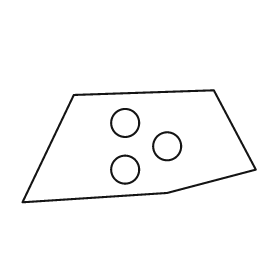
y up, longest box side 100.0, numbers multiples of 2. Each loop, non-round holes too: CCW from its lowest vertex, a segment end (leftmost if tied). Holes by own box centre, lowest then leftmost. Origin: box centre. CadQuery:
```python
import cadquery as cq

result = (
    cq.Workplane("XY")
    .moveTo(-50.0, -24.0)
    .lineTo(12.0, -20.0)
    .lineTo(50.0, -10.0)
    .lineTo(32.0, 24.0)
    .lineTo(-28.0, 22.0)
    .close()
    .moveTo(-6.0, -10.0)
    .circle(6.0)
    .moveTo(12.0, 0.0)
    .circle(6.0)
    .moveTo(-6.0, 10.0)
    .circle(6.0)
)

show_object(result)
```